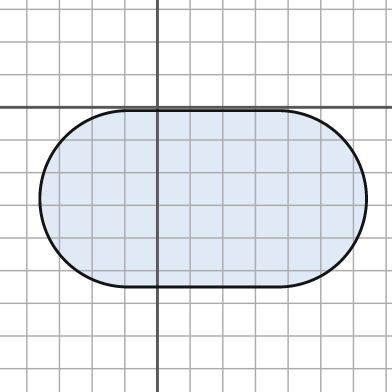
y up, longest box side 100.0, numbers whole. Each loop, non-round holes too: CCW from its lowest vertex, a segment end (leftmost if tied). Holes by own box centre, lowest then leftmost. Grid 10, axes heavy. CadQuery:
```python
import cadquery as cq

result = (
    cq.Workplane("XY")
    .moveTo(-9.0, -55.0)
    .lineTo(37.0, -55.0)
    .threePointArc((64.0, -28.0), (37.0, -1.0))
    .lineTo(-9.0, -1.0)
    .threePointArc((-36.0, -28.0), (-9.0, -55.0))
    .close()
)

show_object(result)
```